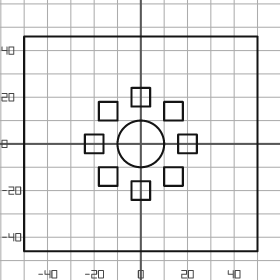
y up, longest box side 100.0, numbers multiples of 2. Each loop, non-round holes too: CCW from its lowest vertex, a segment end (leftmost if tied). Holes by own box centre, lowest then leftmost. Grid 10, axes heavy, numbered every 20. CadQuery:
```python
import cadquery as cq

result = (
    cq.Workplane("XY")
    .moveTo(-50.0, -46.0)
    .lineTo(50.0, -46.0)
    .lineTo(50.0, 46.0)
    .lineTo(-50.0, 46.0)
    .close()
    .moveTo(-4.0, -24.0)
    .lineTo(4.0, -24.0)
    .lineTo(4.0, -16.0)
    .lineTo(-4.0, -16.0)
    .close()
    .moveTo(-18.0, -18.0)
    .lineTo(-10.0, -18.0)
    .lineTo(-10.0, -10.0)
    .lineTo(-18.0, -10.0)
    .close()
    .moveTo(10.0, -18.0)
    .lineTo(18.0, -18.0)
    .lineTo(18.0, -10.0)
    .lineTo(10.0, -10.0)
    .close()
    .moveTo(-24.0, -4.0)
    .lineTo(-16.0, -4.0)
    .lineTo(-16.0, 4.0)
    .lineTo(-24.0, 4.0)
    .close()
    .moveTo(0.0, 0.0)
    .circle(10.0)
    .moveTo(16.0, -4.0)
    .lineTo(24.0, -4.0)
    .lineTo(24.0, 4.0)
    .lineTo(16.0, 4.0)
    .close()
    .moveTo(-18.0, 10.0)
    .lineTo(-10.0, 10.0)
    .lineTo(-10.0, 18.0)
    .lineTo(-18.0, 18.0)
    .close()
    .moveTo(10.0, 10.0)
    .lineTo(18.0, 10.0)
    .lineTo(18.0, 18.0)
    .lineTo(10.0, 18.0)
    .close()
    .moveTo(-4.0, 16.0)
    .lineTo(4.0, 16.0)
    .lineTo(4.0, 24.0)
    .lineTo(-4.0, 24.0)
    .close()
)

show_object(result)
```